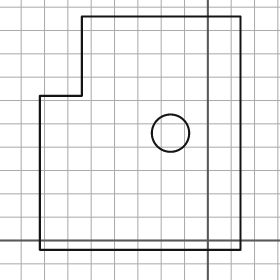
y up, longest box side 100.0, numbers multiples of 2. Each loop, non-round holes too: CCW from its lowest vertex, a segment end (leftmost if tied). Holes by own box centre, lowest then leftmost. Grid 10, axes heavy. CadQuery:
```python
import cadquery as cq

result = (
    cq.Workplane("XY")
    .moveTo(-72.0, -4.0)
    .lineTo(14.0, -4.0)
    .lineTo(14.0, 96.0)
    .lineTo(-54.0, 96.0)
    .lineTo(-54.0, 62.0)
    .lineTo(-72.0, 62.0)
    .close()
    .moveTo(-16.0, 46.0)
    .circle(8.0)
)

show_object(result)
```